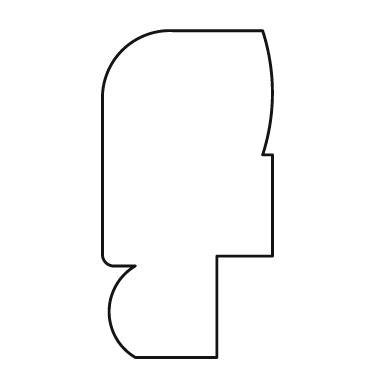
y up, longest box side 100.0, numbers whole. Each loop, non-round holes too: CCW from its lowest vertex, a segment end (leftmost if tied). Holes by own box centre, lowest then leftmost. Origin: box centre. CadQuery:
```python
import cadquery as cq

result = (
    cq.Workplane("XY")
    .moveTo(-16.0, -50.0)
    .lineTo(9.0, -50.0)
    .lineTo(9.0, -19.0)
    .lineTo(26.0, -19.0)
    .lineTo(26.0, 12.0)
    .lineTo(23.0, 12.0)
    .threePointArc((26.0, 31.0), (23.0, 50.0))
    .lineTo(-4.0, 50.0)
    .threePointArc((-20.0, 44.0), (-26.0, 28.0))
    .lineTo(-26.0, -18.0)
    .threePointArc((-25.0, -21.0), (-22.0, -22.0))
    .lineTo(-16.0, -22.0)
    .threePointArc((-24.0, -36.0), (-16.0, -50.0))
    .close()
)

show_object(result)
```